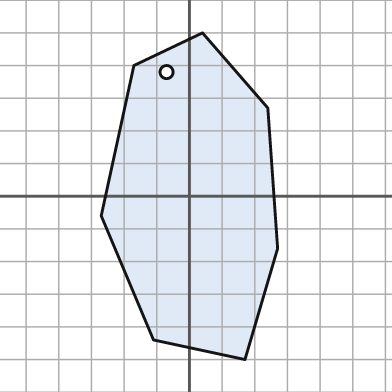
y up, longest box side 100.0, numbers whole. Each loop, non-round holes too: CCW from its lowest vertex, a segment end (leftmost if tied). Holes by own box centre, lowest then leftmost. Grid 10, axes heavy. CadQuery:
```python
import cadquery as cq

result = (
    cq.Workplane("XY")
    .moveTo(17.0, -50.0)
    .lineTo(27.0, -16.0)
    .lineTo(24.0, 27.0)
    .lineTo(4.0, 50.0)
    .lineTo(-17.0, 40.0)
    .lineTo(-27.0, -6.0)
    .lineTo(-11.0, -44.0)
    .close()
    .moveTo(-7.0, 38.0)
    .circle(2.0)
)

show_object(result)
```